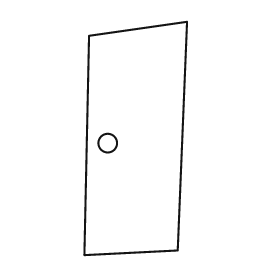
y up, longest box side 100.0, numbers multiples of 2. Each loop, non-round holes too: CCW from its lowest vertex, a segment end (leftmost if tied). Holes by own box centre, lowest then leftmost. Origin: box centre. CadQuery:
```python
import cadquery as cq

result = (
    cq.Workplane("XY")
    .moveTo(-22.0, -50.0)
    .lineTo(18.0, -48.0)
    .lineTo(22.0, 50.0)
    .lineTo(-20.0, 44.0)
    .close()
    .moveTo(-12.0, -2.0)
    .circle(4.0)
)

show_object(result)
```